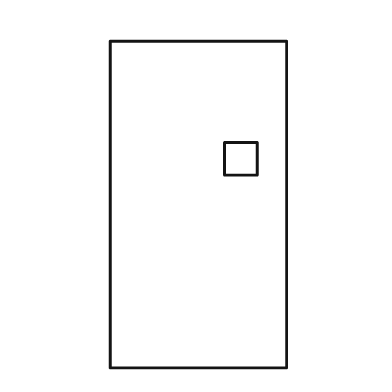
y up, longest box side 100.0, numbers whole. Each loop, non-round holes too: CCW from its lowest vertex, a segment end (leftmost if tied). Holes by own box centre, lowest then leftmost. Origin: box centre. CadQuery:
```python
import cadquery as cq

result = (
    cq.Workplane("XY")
    .moveTo(-27.0, -50.0)
    .lineTo(27.0, -50.0)
    .lineTo(27.0, 50.0)
    .lineTo(-27.0, 50.0)
    .close()
    .moveTo(8.0, 9.0)
    .lineTo(18.0, 9.0)
    .lineTo(18.0, 19.0)
    .lineTo(8.0, 19.0)
    .close()
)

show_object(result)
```